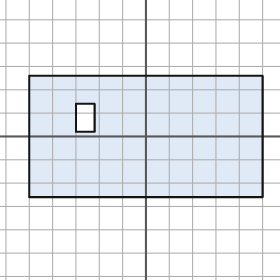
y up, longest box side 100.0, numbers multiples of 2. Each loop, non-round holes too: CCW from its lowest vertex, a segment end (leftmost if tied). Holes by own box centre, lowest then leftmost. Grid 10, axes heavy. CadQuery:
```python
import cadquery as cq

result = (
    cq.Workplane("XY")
    .moveTo(-50.0, -26.0)
    .lineTo(50.0, -26.0)
    .lineTo(50.0, 26.0)
    .lineTo(-50.0, 26.0)
    .close()
    .moveTo(-30.0, 2.0)
    .lineTo(-22.0, 2.0)
    .lineTo(-22.0, 14.0)
    .lineTo(-30.0, 14.0)
    .close()
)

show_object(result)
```